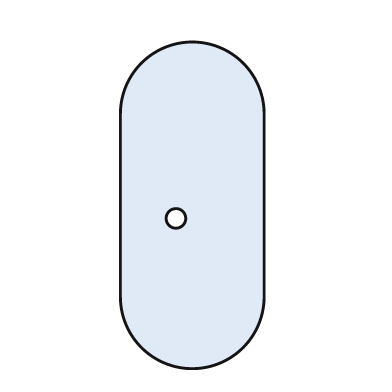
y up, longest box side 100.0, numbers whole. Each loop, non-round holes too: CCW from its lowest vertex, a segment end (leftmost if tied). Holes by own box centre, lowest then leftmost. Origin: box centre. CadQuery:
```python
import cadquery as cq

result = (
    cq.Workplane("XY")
    .moveTo(-22.0, -28.0)
    .threePointArc((0.0, -50.0), (22.0, -28.0))
    .lineTo(22.0, 28.0)
    .threePointArc((0.0, 50.0), (-22.0, 28.0))
    .close()
    .moveTo(-5.0, -4.0)
    .circle(3.0)
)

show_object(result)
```